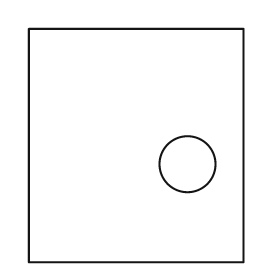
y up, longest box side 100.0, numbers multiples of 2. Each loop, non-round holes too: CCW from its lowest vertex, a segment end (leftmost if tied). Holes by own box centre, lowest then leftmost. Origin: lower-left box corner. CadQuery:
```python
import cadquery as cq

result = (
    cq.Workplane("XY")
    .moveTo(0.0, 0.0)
    .lineTo(92.0, 0.0)
    .lineTo(92.0, 100.0)
    .lineTo(0.0, 100.0)
    .close()
    .moveTo(68.0, 42.0)
    .circle(12.0)
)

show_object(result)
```